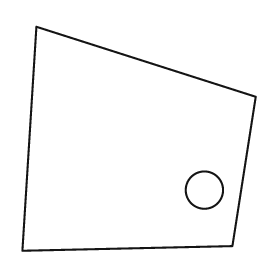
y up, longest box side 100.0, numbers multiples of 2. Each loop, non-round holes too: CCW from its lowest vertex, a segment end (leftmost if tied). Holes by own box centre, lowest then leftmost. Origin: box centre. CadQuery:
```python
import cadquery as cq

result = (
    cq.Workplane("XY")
    .moveTo(-50.0, -48.0)
    .lineTo(40.0, -46.0)
    .lineTo(50.0, 18.0)
    .lineTo(-44.0, 48.0)
    .close()
    .moveTo(28.0, -22.0)
    .circle(8.0)
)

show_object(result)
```